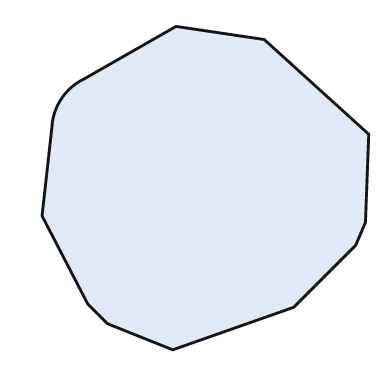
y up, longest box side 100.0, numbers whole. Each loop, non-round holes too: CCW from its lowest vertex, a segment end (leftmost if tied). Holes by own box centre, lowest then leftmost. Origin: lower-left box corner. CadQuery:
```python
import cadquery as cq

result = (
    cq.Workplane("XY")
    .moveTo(40.0, 0.0)
    .lineTo(77.0, 13.0)
    .lineTo(96.0, 32.0)
    .lineTo(99.0, 39.0)
    .lineTo(100.0, 66.0)
    .lineTo(68.0, 95.0)
    .lineTo(41.0, 99.0)
    .lineTo(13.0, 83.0)
    .threePointArc((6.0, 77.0), (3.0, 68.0))
    .lineTo(0.0, 41.0)
    .lineTo(14.0, 14.0)
    .lineTo(20.0, 8.0)
    .close()
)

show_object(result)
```